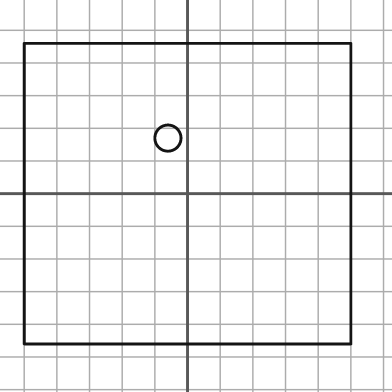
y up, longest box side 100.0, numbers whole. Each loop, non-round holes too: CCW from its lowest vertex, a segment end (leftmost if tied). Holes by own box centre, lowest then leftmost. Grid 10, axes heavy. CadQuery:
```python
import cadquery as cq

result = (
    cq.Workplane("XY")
    .moveTo(-50.0, -46.0)
    .lineTo(50.0, -46.0)
    .lineTo(50.0, 46.0)
    .lineTo(-50.0, 46.0)
    .close()
    .moveTo(-6.0, 17.0)
    .circle(4.0)
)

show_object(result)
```